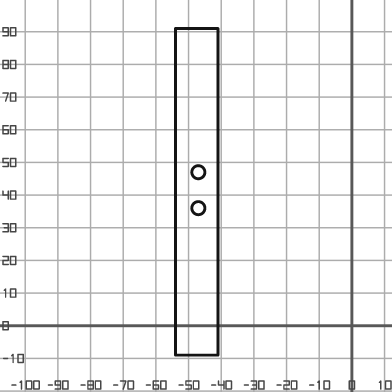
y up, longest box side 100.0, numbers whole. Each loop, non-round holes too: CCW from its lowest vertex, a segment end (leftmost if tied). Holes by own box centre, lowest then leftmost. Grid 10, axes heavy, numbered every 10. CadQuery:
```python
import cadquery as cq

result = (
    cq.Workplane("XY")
    .moveTo(-54.0, -9.0)
    .lineTo(-41.0, -9.0)
    .lineTo(-41.0, 91.0)
    .lineTo(-54.0, 91.0)
    .close()
    .moveTo(-47.0, 36.0)
    .circle(2.0)
    .moveTo(-47.0, 47.0)
    .circle(2.0)
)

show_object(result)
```